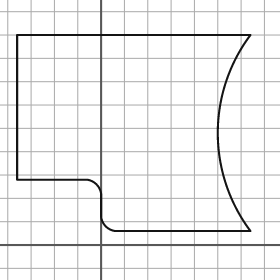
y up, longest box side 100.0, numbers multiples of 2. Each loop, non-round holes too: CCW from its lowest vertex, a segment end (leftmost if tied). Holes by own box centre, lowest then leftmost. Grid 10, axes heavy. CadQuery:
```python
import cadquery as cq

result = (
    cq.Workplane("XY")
    .moveTo(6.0, 6.0)
    .lineTo(64.0, 6.0)
    .threePointArc((50.0, 48.0), (64.0, 90.0))
    .lineTo(-36.0, 90.0)
    .lineTo(-36.0, 28.0)
    .lineTo(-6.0, 28.0)
    .threePointArc((-2.0, 26.0), (0.0, 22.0))
    .lineTo(0.0, 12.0)
    .threePointArc((2.0, 8.0), (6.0, 6.0))
    .close()
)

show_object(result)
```